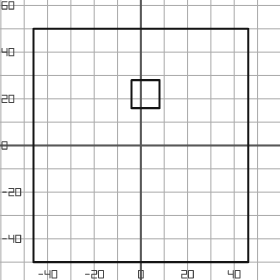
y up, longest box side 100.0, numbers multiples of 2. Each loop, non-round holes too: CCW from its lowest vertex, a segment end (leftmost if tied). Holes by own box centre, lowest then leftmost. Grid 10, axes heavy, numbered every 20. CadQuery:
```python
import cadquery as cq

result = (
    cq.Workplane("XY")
    .moveTo(-46.0, -50.0)
    .lineTo(46.0, -50.0)
    .lineTo(46.0, 50.0)
    .lineTo(-46.0, 50.0)
    .close()
    .moveTo(-4.0, 16.0)
    .lineTo(8.0, 16.0)
    .lineTo(8.0, 28.0)
    .lineTo(-4.0, 28.0)
    .close()
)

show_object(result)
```